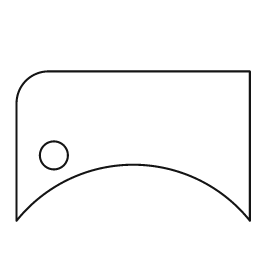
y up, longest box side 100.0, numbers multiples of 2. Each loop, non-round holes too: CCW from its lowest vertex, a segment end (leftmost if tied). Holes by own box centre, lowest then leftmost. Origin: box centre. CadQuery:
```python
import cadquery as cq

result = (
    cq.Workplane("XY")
    .moveTo(-50.0, -32.0)
    .threePointArc((0.0, -8.0), (50.0, -32.0))
    .lineTo(50.0, 32.0)
    .lineTo(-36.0, 32.0)
    .threePointArc((-46.0, 28.0), (-50.0, 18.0))
    .close()
    .moveTo(-34.0, -4.0)
    .circle(6.0)
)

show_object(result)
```